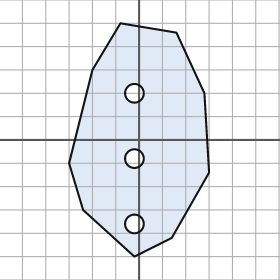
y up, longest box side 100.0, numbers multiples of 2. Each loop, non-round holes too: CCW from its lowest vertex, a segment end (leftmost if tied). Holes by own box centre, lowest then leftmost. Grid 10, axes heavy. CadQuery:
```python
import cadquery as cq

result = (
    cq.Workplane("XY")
    .moveTo(-2.0, -50.0)
    .lineTo(14.0, -42.0)
    .lineTo(30.0, -14.0)
    .lineTo(28.0, 20.0)
    .lineTo(16.0, 46.0)
    .lineTo(-8.0, 50.0)
    .lineTo(-20.0, 30.0)
    .lineTo(-30.0, -10.0)
    .lineTo(-24.0, -30.0)
    .close()
    .moveTo(-2.0, -36.0)
    .circle(4.0)
    .moveTo(-2.0, -8.0)
    .circle(4.0)
    .moveTo(-2.0, 20.0)
    .circle(4.0)
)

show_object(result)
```